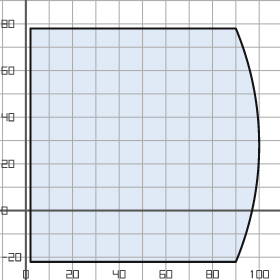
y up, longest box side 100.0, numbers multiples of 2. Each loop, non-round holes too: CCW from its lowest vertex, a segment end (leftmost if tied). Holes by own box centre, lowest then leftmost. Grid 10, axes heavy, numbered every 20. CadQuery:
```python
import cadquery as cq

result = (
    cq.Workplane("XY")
    .moveTo(2.0, -22.0)
    .lineTo(90.0, -22.0)
    .threePointArc((100.0, 28.0), (90.0, 78.0))
    .lineTo(2.0, 78.0)
    .close()
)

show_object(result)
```